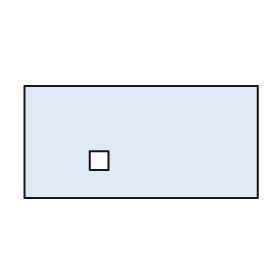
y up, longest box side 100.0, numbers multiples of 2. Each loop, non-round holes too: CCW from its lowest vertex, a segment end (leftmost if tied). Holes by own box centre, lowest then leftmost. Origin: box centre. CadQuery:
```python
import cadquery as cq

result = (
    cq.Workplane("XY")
    .moveTo(-50.0, -24.0)
    .lineTo(50.0, -24.0)
    .lineTo(50.0, 24.0)
    .lineTo(-50.0, 24.0)
    .close()
    .moveTo(-22.0, -12.0)
    .lineTo(-14.0, -12.0)
    .lineTo(-14.0, -4.0)
    .lineTo(-22.0, -4.0)
    .close()
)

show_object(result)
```